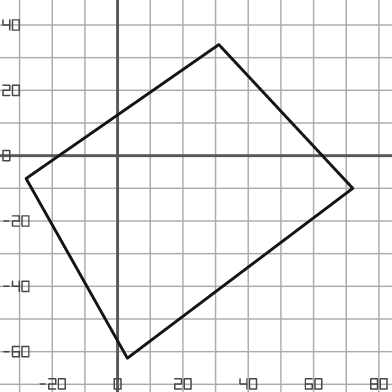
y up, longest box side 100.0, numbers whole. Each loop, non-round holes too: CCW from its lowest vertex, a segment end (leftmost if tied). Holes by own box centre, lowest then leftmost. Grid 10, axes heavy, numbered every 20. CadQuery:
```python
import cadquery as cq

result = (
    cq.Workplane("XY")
    .moveTo(3.0, -62.0)
    .lineTo(72.0, -10.0)
    .lineTo(31.0, 34.0)
    .lineTo(-28.0, -7.0)
    .close()
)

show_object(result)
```